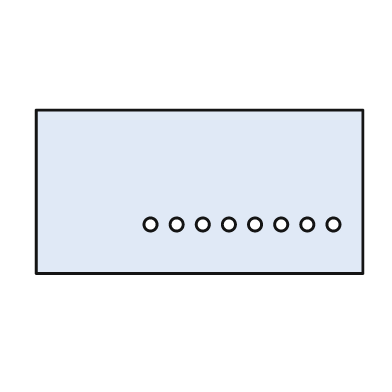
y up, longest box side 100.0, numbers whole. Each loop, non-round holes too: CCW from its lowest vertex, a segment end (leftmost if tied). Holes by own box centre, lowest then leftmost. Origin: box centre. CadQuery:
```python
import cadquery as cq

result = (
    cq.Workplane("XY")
    .moveTo(-50.0, -25.0)
    .lineTo(50.0, -25.0)
    .lineTo(50.0, 25.0)
    .lineTo(-50.0, 25.0)
    .close()
    .moveTo(-15.0, -10.0)
    .circle(2.0)
    .moveTo(-7.0, -10.0)
    .circle(2.0)
    .moveTo(1.0, -10.0)
    .circle(2.0)
    .moveTo(9.0, -10.0)
    .circle(2.0)
    .moveTo(17.0, -10.0)
    .circle(2.0)
    .moveTo(25.0, -10.0)
    .circle(2.0)
    .moveTo(33.0, -10.0)
    .circle(2.0)
    .moveTo(41.0, -10.0)
    .circle(2.0)
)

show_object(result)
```